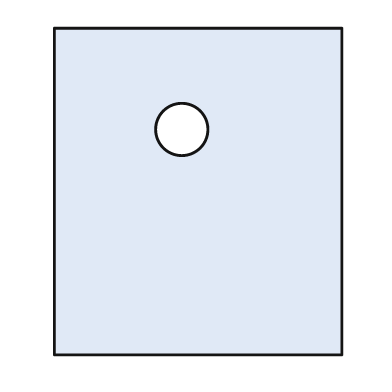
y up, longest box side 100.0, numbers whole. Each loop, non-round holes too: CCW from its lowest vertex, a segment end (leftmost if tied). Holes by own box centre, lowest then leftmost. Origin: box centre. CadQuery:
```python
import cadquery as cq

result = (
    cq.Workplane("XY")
    .moveTo(-44.0, -50.0)
    .lineTo(44.0, -50.0)
    .lineTo(44.0, 50.0)
    .lineTo(-44.0, 50.0)
    .close()
    .moveTo(-5.0, 19.0)
    .circle(8.0)
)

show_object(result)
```